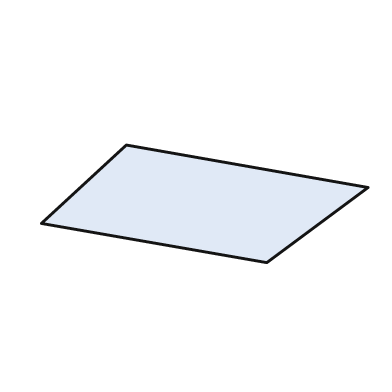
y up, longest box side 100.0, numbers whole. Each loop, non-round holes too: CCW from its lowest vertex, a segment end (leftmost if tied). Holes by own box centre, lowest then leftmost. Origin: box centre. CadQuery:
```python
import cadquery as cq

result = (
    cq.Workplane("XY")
    .moveTo(19.0, -18.0)
    .lineTo(50.0, 5.0)
    .lineTo(-24.0, 18.0)
    .lineTo(-50.0, -6.0)
    .close()
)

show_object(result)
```